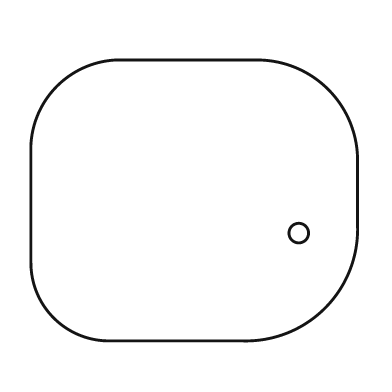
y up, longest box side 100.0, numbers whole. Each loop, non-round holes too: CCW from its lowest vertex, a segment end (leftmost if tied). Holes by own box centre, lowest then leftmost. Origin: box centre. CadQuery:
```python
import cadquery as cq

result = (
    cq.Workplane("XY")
    .moveTo(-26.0, -43.0)
    .lineTo(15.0, -43.0)
    .threePointArc((40.0, -33.0), (50.0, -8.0))
    .lineTo(50.0, 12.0)
    .threePointArc((41.0, 34.0), (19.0, 43.0))
    .lineTo(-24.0, 43.0)
    .threePointArc((-42.0, 35.0), (-50.0, 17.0))
    .lineTo(-50.0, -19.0)
    .threePointArc((-43.0, -36.0), (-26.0, -43.0))
    .close()
    .moveTo(32.0, -10.0)
    .circle(3.0)
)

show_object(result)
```